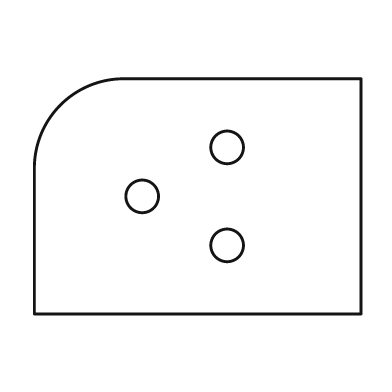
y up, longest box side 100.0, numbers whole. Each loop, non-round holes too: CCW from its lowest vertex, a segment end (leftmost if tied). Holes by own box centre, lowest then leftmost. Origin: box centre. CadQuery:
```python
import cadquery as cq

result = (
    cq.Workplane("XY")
    .moveTo(-50.0, -36.0)
    .lineTo(50.0, -36.0)
    .lineTo(50.0, 36.0)
    .lineTo(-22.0, 36.0)
    .threePointArc((-42.0, 28.0), (-50.0, 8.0))
    .close()
    .moveTo(9.0, -15.0)
    .circle(5.0)
    .moveTo(-17.0, 0.0)
    .circle(5.0)
    .moveTo(9.0, 15.0)
    .circle(5.0)
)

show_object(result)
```